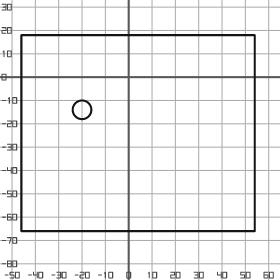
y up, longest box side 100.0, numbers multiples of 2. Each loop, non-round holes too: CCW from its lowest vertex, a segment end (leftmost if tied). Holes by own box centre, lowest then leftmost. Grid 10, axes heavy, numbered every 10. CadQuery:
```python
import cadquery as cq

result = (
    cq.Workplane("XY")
    .moveTo(-46.0, -66.0)
    .lineTo(54.0, -66.0)
    .lineTo(54.0, 18.0)
    .lineTo(-46.0, 18.0)
    .close()
    .moveTo(-20.0, -14.0)
    .circle(4.0)
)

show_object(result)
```